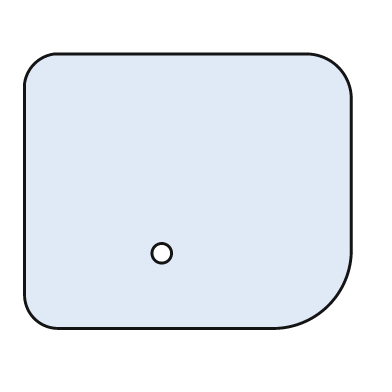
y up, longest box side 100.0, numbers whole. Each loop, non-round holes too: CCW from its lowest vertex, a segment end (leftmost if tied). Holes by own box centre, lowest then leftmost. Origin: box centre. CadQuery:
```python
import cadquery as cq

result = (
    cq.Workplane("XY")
    .moveTo(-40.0, -42.0)
    .lineTo(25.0, -42.0)
    .threePointArc((43.0, -35.0), (50.0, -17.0))
    .lineTo(50.0, 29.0)
    .threePointArc((46.0, 38.0), (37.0, 42.0))
    .lineTo(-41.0, 42.0)
    .threePointArc((-47.0, 39.0), (-50.0, 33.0))
    .lineTo(-50.0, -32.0)
    .threePointArc((-47.0, -39.0), (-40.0, -42.0))
    .close()
    .moveTo(-8.0, -19.0)
    .circle(3.0)
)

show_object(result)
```